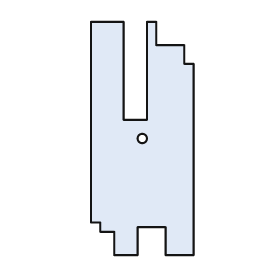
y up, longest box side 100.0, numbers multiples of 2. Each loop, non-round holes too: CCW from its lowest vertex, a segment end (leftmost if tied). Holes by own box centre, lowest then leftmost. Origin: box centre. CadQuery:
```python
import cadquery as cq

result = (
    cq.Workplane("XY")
    .moveTo(-12.0, -50.0)
    .lineTo(-2.0, -50.0)
    .lineTo(-2.0, -38.0)
    .lineTo(10.0, -38.0)
    .lineTo(10.0, -50.0)
    .lineTo(22.0, -50.0)
    .lineTo(22.0, 32.0)
    .lineTo(18.0, 32.0)
    .lineTo(18.0, 40.0)
    .lineTo(6.0, 40.0)
    .lineTo(6.0, 50.0)
    .lineTo(2.0, 50.0)
    .lineTo(2.0, 8.0)
    .lineTo(-8.0, 8.0)
    .lineTo(-8.0, 50.0)
    .lineTo(-22.0, 50.0)
    .lineTo(-22.0, -36.0)
    .lineTo(-18.0, -36.0)
    .lineTo(-18.0, -40.0)
    .lineTo(-12.0, -40.0)
    .close()
    .moveTo(0.0, 0.0)
    .circle(2.0)
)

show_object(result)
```